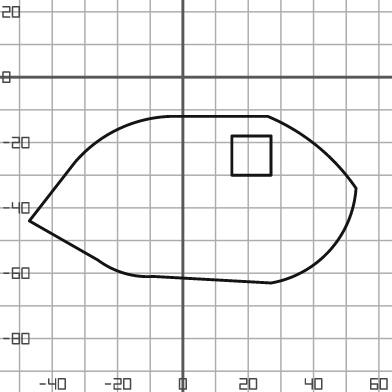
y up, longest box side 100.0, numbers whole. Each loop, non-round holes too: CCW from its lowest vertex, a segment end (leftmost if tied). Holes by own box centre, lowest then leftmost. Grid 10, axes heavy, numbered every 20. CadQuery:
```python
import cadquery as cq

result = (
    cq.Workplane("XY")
    .moveTo(27.0, -63.0)
    .threePointArc((45.0, -53.0), (53.0, -34.0))
    .threePointArc((41.0, -21.0), (26.0, -12.0))
    .lineTo(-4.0, -12.0)
    .threePointArc((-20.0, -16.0), (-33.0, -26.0))
    .lineTo(-47.0, -44.0)
    .lineTo(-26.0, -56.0)
    .threePointArc((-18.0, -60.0), (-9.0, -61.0))
    .close()
    .moveTo(15.0, -30.0)
    .lineTo(27.0, -30.0)
    .lineTo(27.0, -18.0)
    .lineTo(15.0, -18.0)
    .close()
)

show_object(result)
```